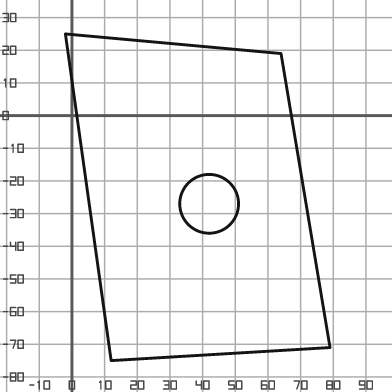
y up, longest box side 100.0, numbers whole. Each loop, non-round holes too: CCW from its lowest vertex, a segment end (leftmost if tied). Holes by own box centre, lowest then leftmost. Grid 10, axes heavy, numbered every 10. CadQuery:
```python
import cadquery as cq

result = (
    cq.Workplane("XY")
    .moveTo(12.0, -75.0)
    .lineTo(79.0, -71.0)
    .lineTo(64.0, 19.0)
    .lineTo(-2.0, 25.0)
    .close()
    .moveTo(42.0, -27.0)
    .circle(9.0)
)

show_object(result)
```